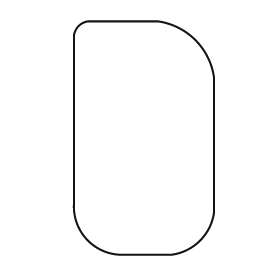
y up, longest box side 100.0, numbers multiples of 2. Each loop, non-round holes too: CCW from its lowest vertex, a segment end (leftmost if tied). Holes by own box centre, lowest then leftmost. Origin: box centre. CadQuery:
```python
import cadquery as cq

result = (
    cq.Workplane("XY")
    .moveTo(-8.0, -50.0)
    .lineTo(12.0, -50.0)
    .threePointArc((24.0, -44.0), (30.0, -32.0))
    .lineTo(30.0, 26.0)
    .threePointArc((22.0, 42.0), (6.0, 50.0))
    .lineTo(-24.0, 50.0)
    .threePointArc((-28.0, 48.0), (-30.0, 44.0))
    .lineTo(-30.0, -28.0)
    .threePointArc((-24.0, -44.0), (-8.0, -50.0))
    .close()
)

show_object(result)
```